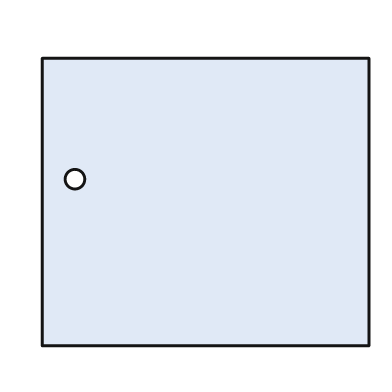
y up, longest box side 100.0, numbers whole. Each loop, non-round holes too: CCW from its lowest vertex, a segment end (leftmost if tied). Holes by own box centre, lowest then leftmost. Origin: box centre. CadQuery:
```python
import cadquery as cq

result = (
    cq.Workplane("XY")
    .moveTo(-50.0, -44.0)
    .lineTo(50.0, -44.0)
    .lineTo(50.0, 44.0)
    .lineTo(-50.0, 44.0)
    .close()
    .moveTo(-40.0, 7.0)
    .circle(3.0)
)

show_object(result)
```